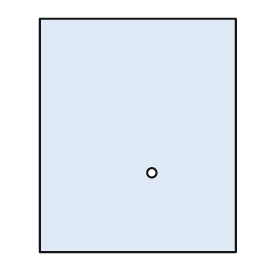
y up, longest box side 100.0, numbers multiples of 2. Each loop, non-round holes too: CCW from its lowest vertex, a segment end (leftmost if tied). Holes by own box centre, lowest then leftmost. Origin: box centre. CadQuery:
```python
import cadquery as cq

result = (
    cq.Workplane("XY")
    .moveTo(-42.0, -50.0)
    .lineTo(42.0, -50.0)
    .lineTo(42.0, 50.0)
    .lineTo(-42.0, 50.0)
    .close()
    .moveTo(6.0, -16.0)
    .circle(2.0)
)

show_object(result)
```